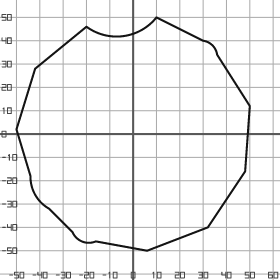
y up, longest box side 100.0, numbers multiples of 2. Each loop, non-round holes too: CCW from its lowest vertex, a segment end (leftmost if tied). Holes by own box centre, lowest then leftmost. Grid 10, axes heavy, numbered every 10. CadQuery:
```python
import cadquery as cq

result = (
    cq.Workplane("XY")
    .moveTo(6.0, -50.0)
    .lineTo(32.0, -40.0)
    .lineTo(48.0, -16.0)
    .lineTo(50.0, 12.0)
    .lineTo(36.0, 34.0)
    .threePointArc((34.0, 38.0), (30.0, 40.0))
    .lineTo(10.0, 50.0)
    .threePointArc((-4.0, 42.0), (-20.0, 46.0))
    .lineTo(-42.0, 28.0)
    .lineTo(-50.0, 2.0)
    .lineTo(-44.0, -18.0)
    .threePointArc((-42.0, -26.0), (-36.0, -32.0))
    .lineTo(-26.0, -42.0)
    .threePointArc((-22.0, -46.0), (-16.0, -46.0))
    .close()
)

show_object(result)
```